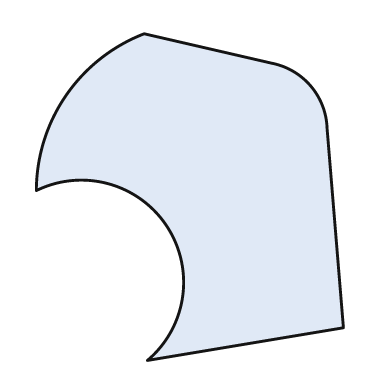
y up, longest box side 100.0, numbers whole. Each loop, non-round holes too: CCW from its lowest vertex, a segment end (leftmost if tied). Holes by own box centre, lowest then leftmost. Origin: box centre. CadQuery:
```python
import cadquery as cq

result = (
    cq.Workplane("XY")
    .moveTo(-13.0, -50.0)
    .lineTo(47.0, -40.0)
    .lineTo(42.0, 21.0)
    .threePointArc((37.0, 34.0), (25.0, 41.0))
    .lineTo(-14.0, 50.0)
    .threePointArc((-38.0, 31.0), (-47.0, 2.0))
    .threePointArc((-7.0, -9.0), (-13.0, -50.0))
    .close()
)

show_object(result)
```